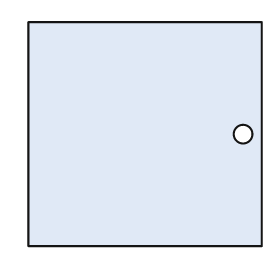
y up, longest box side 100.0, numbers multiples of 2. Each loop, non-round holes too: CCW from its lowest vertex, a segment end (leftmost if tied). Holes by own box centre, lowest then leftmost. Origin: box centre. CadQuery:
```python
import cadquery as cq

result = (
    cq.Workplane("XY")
    .moveTo(-50.0, -48.0)
    .lineTo(50.0, -48.0)
    .lineTo(50.0, 48.0)
    .lineTo(-50.0, 48.0)
    .close()
    .moveTo(42.0, 0.0)
    .circle(4.0)
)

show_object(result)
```